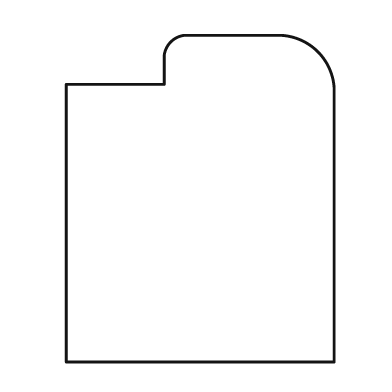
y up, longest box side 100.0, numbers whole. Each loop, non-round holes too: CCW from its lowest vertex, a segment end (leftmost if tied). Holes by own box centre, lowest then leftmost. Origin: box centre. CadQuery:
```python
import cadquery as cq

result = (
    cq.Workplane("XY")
    .moveTo(-41.0, -50.0)
    .lineTo(41.0, -50.0)
    .lineTo(41.0, 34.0)
    .threePointArc((36.0, 45.0), (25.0, 50.0))
    .lineTo(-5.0, 50.0)
    .threePointArc((-9.0, 48.0), (-11.0, 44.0))
    .lineTo(-11.0, 35.0)
    .lineTo(-41.0, 35.0)
    .close()
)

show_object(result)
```